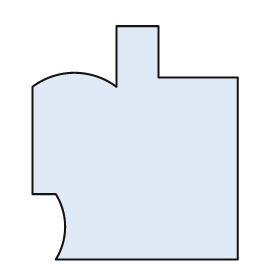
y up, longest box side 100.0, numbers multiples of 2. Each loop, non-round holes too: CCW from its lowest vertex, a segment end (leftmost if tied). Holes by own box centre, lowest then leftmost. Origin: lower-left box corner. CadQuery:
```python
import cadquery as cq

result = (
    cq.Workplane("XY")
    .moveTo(10.0, 0.0)
    .lineTo(88.0, 0.0)
    .lineTo(88.0, 78.0)
    .lineTo(54.0, 78.0)
    .lineTo(54.0, 100.0)
    .lineTo(36.0, 100.0)
    .lineTo(36.0, 74.0)
    .threePointArc((18.0, 80.0), (0.0, 74.0))
    .lineTo(0.0, 28.0)
    .lineTo(10.0, 28.0)
    .threePointArc((14.0, 14.0), (10.0, 0.0))
    .close()
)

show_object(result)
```